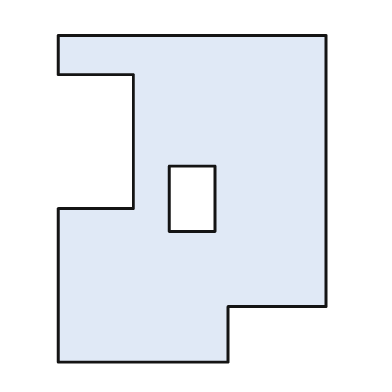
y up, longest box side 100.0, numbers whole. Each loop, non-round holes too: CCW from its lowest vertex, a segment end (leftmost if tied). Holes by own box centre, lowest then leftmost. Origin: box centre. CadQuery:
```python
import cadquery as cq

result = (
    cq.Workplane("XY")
    .moveTo(-41.0, -50.0)
    .lineTo(11.0, -50.0)
    .lineTo(11.0, -33.0)
    .lineTo(41.0, -33.0)
    .lineTo(41.0, 50.0)
    .lineTo(-41.0, 50.0)
    .lineTo(-41.0, 38.0)
    .lineTo(-18.0, 38.0)
    .lineTo(-18.0, -3.0)
    .lineTo(-41.0, -3.0)
    .close()
    .moveTo(-7.0, -10.0)
    .lineTo(7.0, -10.0)
    .lineTo(7.0, 10.0)
    .lineTo(-7.0, 10.0)
    .close()
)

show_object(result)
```